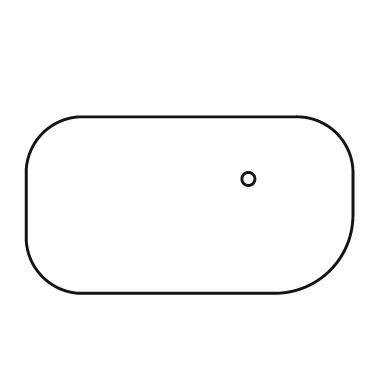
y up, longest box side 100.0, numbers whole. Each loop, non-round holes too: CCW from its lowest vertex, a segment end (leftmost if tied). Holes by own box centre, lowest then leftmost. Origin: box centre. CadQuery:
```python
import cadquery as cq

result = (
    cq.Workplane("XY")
    .moveTo(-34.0, -27.0)
    .lineTo(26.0, -27.0)
    .threePointArc((43.0, -20.0), (50.0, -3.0))
    .lineTo(50.0, 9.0)
    .threePointArc((45.0, 22.0), (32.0, 27.0))
    .lineTo(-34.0, 27.0)
    .threePointArc((-45.0, 22.0), (-50.0, 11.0))
    .lineTo(-50.0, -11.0)
    .threePointArc((-45.0, -22.0), (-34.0, -27.0))
    .close()
    .moveTo(18.0, 8.0)
    .circle(2.0)
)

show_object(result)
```